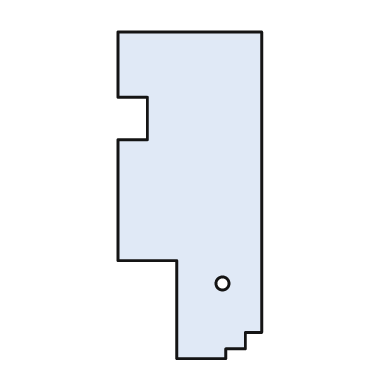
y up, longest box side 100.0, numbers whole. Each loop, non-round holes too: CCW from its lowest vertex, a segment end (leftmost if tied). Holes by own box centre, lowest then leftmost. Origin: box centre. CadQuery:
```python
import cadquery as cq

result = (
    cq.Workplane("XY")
    .moveTo(-4.0, -50.0)
    .lineTo(11.0, -50.0)
    .lineTo(11.0, -47.0)
    .lineTo(17.0, -47.0)
    .lineTo(17.0, -42.0)
    .lineTo(22.0, -42.0)
    .lineTo(22.0, 50.0)
    .lineTo(-22.0, 50.0)
    .lineTo(-22.0, 30.0)
    .lineTo(-13.0, 30.0)
    .lineTo(-13.0, 17.0)
    .lineTo(-22.0, 17.0)
    .lineTo(-22.0, -20.0)
    .lineTo(-4.0, -20.0)
    .close()
    .moveTo(10.0, -27.0)
    .circle(2.0)
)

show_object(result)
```